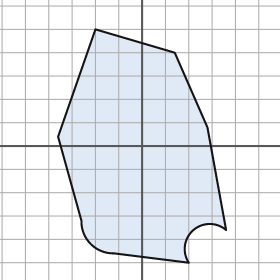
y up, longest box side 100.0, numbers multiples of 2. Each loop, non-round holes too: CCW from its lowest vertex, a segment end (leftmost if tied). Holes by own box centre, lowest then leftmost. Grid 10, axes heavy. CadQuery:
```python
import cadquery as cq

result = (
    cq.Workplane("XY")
    .moveTo(20.0, -50.0)
    .threePointArc((22.0, -36.0), (36.0, -36.0))
    .lineTo(28.0, 8.0)
    .lineTo(14.0, 40.0)
    .lineTo(-20.0, 50.0)
    .lineTo(-36.0, 4.0)
    .lineTo(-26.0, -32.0)
    .threePointArc((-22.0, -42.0), (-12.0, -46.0))
    .close()
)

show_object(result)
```